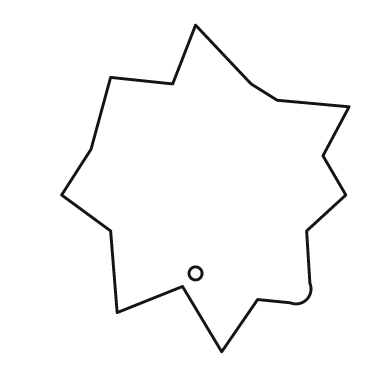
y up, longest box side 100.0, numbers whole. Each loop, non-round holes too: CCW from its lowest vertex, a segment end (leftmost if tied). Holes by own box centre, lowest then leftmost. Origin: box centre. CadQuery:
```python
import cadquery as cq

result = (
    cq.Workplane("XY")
    .moveTo(5.0, -50.0)
    .lineTo(16.0, -34.0)
    .lineTo(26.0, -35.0)
    .threePointArc((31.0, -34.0), (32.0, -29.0))
    .lineTo(31.0, -13.0)
    .lineTo(43.0, -2.0)
    .lineTo(36.0, 10.0)
    .lineTo(44.0, 25.0)
    .lineTo(22.0, 27.0)
    .lineTo(14.0, 32.0)
    .lineTo(-3.0, 50.0)
    .lineTo(-10.0, 32.0)
    .lineTo(-29.0, 34.0)
    .lineTo(-35.0, 12.0)
    .lineTo(-44.0, -2.0)
    .lineTo(-29.0, -13.0)
    .lineTo(-27.0, -38.0)
    .lineTo(-7.0, -30.0)
    .close()
    .moveTo(-3.0, -26.0)
    .circle(2.0)
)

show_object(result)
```